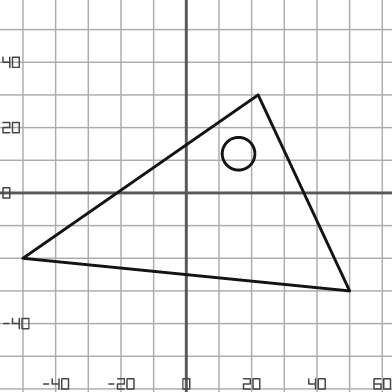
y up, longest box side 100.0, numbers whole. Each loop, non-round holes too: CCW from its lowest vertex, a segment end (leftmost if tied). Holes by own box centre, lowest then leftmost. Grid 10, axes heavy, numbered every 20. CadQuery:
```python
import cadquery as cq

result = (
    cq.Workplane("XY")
    .moveTo(50.0, -30.0)
    .lineTo(22.0, 30.0)
    .lineTo(-50.0, -20.0)
    .close()
    .moveTo(16.0, 12.0)
    .circle(5.0)
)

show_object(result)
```